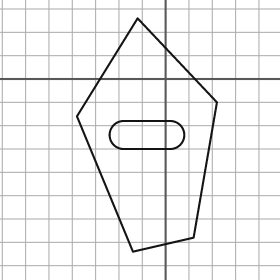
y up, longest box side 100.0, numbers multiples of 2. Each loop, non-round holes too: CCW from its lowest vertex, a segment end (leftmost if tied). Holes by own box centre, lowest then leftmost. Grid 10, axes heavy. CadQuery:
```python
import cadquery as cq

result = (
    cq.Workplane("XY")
    .moveTo(-14.0, -74.0)
    .lineTo(12.0, -68.0)
    .lineTo(22.0, -10.0)
    .lineTo(-12.0, 26.0)
    .lineTo(-38.0, -16.0)
    .close()
    .moveTo(-18.0, -30.0)
    .lineTo(2.0, -30.0)
    .threePointArc((8.0, -24.0), (2.0, -18.0))
    .lineTo(-18.0, -18.0)
    .threePointArc((-24.0, -24.0), (-18.0, -30.0))
    .close()
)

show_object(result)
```